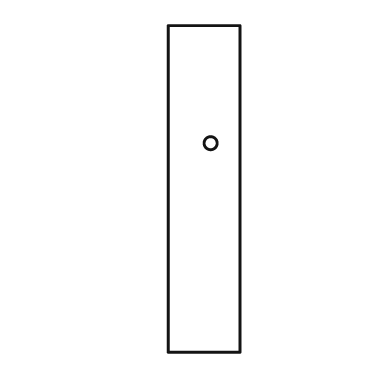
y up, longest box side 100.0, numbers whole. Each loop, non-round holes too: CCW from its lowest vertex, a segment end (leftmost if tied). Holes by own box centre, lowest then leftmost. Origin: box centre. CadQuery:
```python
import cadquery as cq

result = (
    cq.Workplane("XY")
    .moveTo(-11.0, -50.0)
    .lineTo(11.0, -50.0)
    .lineTo(11.0, 50.0)
    .lineTo(-11.0, 50.0)
    .close()
    .moveTo(2.0, 14.0)
    .circle(2.0)
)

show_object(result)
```